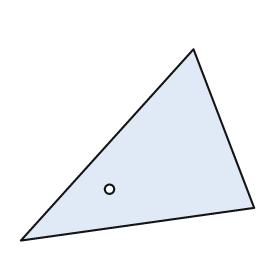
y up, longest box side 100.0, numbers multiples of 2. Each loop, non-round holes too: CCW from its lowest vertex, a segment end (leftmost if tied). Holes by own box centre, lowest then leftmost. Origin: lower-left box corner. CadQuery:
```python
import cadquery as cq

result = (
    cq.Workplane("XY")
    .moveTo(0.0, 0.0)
    .lineTo(100.0, 14.0)
    .lineTo(74.0, 82.0)
    .close()
    .moveTo(38.0, 22.0)
    .circle(2.0)
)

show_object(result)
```